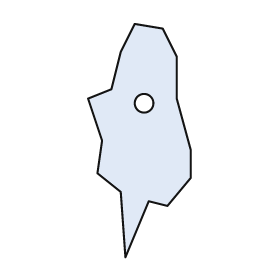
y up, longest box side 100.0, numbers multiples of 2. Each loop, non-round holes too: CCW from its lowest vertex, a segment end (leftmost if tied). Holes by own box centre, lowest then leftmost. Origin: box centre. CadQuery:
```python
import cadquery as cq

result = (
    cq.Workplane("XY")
    .moveTo(-6.0, -50.0)
    .lineTo(4.0, -26.0)
    .lineTo(12.0, -28.0)
    .lineTo(22.0, -16.0)
    .lineTo(22.0, -4.0)
    .lineTo(16.0, 18.0)
    .lineTo(16.0, 36.0)
    .lineTo(10.0, 48.0)
    .lineTo(-2.0, 50.0)
    .lineTo(-8.0, 38.0)
    .lineTo(-12.0, 22.0)
    .lineTo(-22.0, 18.0)
    .lineTo(-16.0, 0.0)
    .lineTo(-18.0, -14.0)
    .lineTo(-8.0, -22.0)
    .close()
    .moveTo(2.0, 16.0)
    .circle(4.0)
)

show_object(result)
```